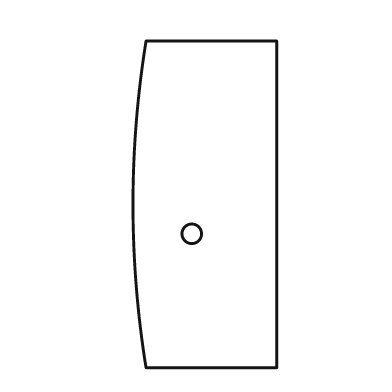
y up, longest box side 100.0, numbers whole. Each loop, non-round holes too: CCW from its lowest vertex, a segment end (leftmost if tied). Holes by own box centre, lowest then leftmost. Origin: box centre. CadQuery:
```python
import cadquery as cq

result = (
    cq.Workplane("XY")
    .moveTo(-18.0, -50.0)
    .lineTo(22.0, -50.0)
    .lineTo(22.0, 50.0)
    .lineTo(-18.0, 50.0)
    .threePointArc((-22.0, 0.0), (-18.0, -50.0))
    .close()
    .moveTo(-4.0, -9.0)
    .circle(3.0)
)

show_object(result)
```